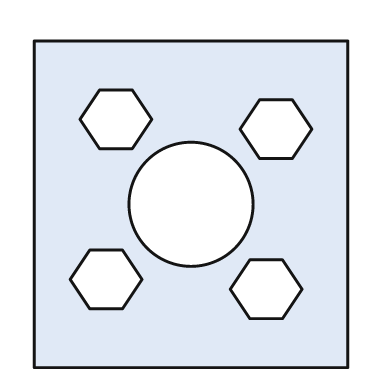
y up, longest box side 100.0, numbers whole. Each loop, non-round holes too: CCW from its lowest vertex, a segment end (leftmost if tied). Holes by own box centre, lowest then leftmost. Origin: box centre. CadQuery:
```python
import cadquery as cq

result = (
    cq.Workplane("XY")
    .moveTo(-48.0, -50.0)
    .lineTo(48.0, -50.0)
    .lineTo(48.0, 50.0)
    .lineTo(-48.0, 50.0)
    .close()
    .moveTo(18.0, -35.0)
    .lineTo(28.0, -35.0)
    .lineTo(34.0, -26.0)
    .lineTo(28.0, -17.0)
    .lineTo(18.0, -17.0)
    .lineTo(12.0, -26.0)
    .close()
    .moveTo(-31.0, -32.0)
    .lineTo(-21.0, -32.0)
    .lineTo(-15.0, -23.0)
    .lineTo(-21.0, -14.0)
    .lineTo(-31.0, -14.0)
    .lineTo(-37.0, -23.0)
    .close()
    .moveTo(0.0, 0.0)
    .circle(19.0)
    .moveTo(21.0, 14.0)
    .lineTo(31.0, 14.0)
    .lineTo(37.0, 23.0)
    .lineTo(31.0, 32.0)
    .lineTo(21.0, 32.0)
    .lineTo(15.0, 23.0)
    .close()
    .moveTo(-28.0, 17.0)
    .lineTo(-18.0, 17.0)
    .lineTo(-12.0, 26.0)
    .lineTo(-18.0, 35.0)
    .lineTo(-28.0, 35.0)
    .lineTo(-34.0, 26.0)
    .close()
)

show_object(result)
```